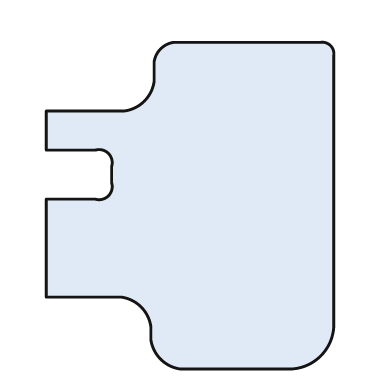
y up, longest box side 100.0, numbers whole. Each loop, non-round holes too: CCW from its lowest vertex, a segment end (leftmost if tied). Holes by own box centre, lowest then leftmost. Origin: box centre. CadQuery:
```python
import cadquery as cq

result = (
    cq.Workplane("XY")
    .moveTo(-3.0, -50.0)
    .lineTo(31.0, -50.0)
    .threePointArc((40.0, -46.0), (44.0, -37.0))
    .lineTo(44.0, 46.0)
    .threePointArc((43.0, 49.0), (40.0, 50.0))
    .lineTo(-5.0, 50.0)
    .threePointArc((-9.0, 48.0), (-11.0, 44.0))
    .lineTo(-11.0, 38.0)
    .threePointArc((-14.0, 32.0), (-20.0, 29.0))
    .lineTo(-44.0, 29.0)
    .lineTo(-44.0, 17.0)
    .lineTo(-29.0, 17.0)
    .threePointArc((-25.0, 16.0), (-24.0, 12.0))
    .lineTo(-24.0, 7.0)
    .threePointArc((-25.0, 3.0), (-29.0, 2.0))
    .lineTo(-44.0, 2.0)
    .lineTo(-44.0, -28.0)
    .lineTo(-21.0, -28.0)
    .threePointArc((-15.0, -31.0), (-12.0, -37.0))
    .lineTo(-12.0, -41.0)
    .threePointArc((-9.0, -47.0), (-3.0, -50.0))
    .close()
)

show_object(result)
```